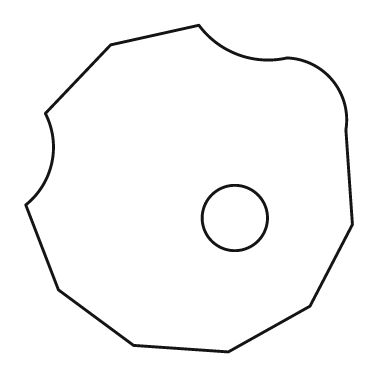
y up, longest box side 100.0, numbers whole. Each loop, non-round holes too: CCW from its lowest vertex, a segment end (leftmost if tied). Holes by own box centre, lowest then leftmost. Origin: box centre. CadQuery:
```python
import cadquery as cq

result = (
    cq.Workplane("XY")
    .moveTo(12.0, -50.0)
    .lineTo(37.0, -36.0)
    .lineTo(50.0, -11.0)
    .lineTo(48.0, 18.0)
    .threePointArc((44.0, 33.0), (30.0, 40.0))
    .threePointArc((15.0, 41.0), (3.0, 50.0))
    .lineTo(-24.0, 44.0)
    .lineTo(-44.0, 23.0)
    .threePointArc((-42.0, 8.0), (-50.0, -5.0))
    .lineTo(-40.0, -31.0)
    .lineTo(-17.0, -48.0)
    .close()
    .moveTo(14.0, -9.0)
    .circle(10.0)
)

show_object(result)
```